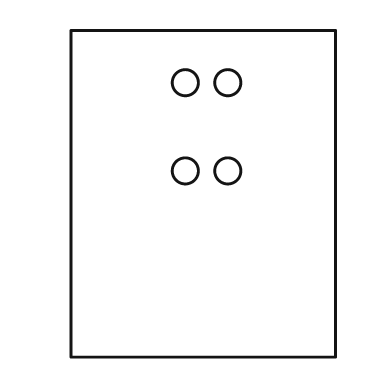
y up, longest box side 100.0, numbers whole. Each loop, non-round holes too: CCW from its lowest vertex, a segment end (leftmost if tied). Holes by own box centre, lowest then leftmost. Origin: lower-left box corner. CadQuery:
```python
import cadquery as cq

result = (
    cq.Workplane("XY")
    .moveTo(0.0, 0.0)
    .lineTo(81.0, 0.0)
    .lineTo(81.0, 100.0)
    .lineTo(0.0, 100.0)
    .close()
    .moveTo(35.0, 57.0)
    .circle(4.0)
    .moveTo(48.0, 57.0)
    .circle(4.0)
    .moveTo(35.0, 84.0)
    .circle(4.0)
    .moveTo(48.0, 84.0)
    .circle(4.0)
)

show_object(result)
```